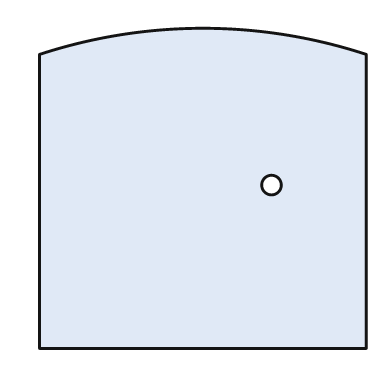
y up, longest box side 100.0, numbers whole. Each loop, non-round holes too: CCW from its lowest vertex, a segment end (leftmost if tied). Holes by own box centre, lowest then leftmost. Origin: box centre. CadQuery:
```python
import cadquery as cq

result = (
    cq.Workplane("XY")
    .moveTo(-50.0, -49.0)
    .lineTo(50.0, -49.0)
    .lineTo(50.0, 41.0)
    .threePointArc((0.0, 49.0), (-50.0, 41.0))
    .close()
    .moveTo(21.0, 1.0)
    .circle(3.0)
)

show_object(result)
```